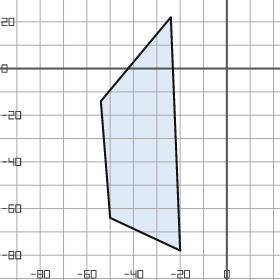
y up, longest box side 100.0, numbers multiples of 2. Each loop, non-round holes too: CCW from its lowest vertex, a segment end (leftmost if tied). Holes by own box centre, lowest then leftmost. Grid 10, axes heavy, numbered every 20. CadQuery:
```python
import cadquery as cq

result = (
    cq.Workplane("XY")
    .moveTo(-20.0, -78.0)
    .lineTo(-24.0, 22.0)
    .lineTo(-54.0, -14.0)
    .lineTo(-50.0, -64.0)
    .close()
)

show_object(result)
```